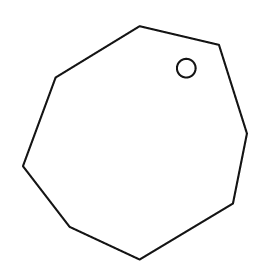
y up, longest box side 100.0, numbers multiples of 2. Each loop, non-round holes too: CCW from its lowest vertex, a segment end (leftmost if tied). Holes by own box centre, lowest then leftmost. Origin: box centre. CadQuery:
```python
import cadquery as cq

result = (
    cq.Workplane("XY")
    .moveTo(2.0, -50.0)
    .lineTo(42.0, -26.0)
    .lineTo(48.0, 4.0)
    .lineTo(36.0, 42.0)
    .lineTo(2.0, 50.0)
    .lineTo(-34.0, 28.0)
    .lineTo(-48.0, -10.0)
    .lineTo(-28.0, -36.0)
    .close()
    .moveTo(22.0, 32.0)
    .circle(4.0)
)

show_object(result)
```